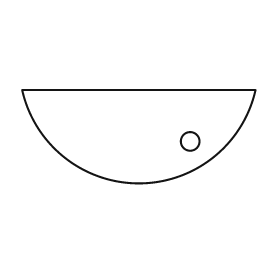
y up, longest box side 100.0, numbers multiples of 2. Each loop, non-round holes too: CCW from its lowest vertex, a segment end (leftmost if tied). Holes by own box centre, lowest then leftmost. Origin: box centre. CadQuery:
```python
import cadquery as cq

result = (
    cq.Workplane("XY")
    .moveTo(-50.0, 20.0)
    .threePointArc((0.0, -20.0), (50.0, 20.0))
    .close()
    .moveTo(22.0, -2.0)
    .circle(4.0)
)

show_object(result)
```